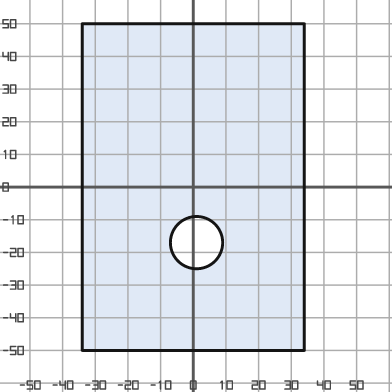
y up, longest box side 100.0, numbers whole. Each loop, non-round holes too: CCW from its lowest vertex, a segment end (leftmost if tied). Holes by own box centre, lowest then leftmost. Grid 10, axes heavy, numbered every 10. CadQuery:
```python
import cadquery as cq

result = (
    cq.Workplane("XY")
    .moveTo(-34.0, -50.0)
    .lineTo(34.0, -50.0)
    .lineTo(34.0, 50.0)
    .lineTo(-34.0, 50.0)
    .close()
    .moveTo(1.0, -17.0)
    .circle(8.0)
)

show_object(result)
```